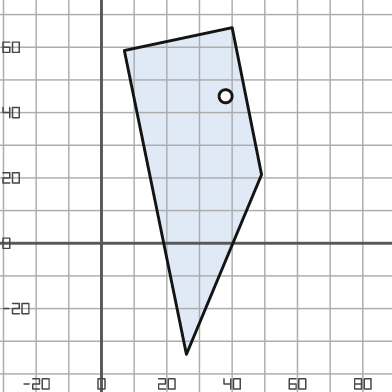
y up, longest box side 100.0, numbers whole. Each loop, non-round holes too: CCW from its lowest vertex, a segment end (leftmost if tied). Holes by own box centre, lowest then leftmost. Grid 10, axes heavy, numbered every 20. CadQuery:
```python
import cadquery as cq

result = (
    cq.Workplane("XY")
    .moveTo(26.0, -34.0)
    .lineTo(49.0, 21.0)
    .lineTo(40.0, 66.0)
    .lineTo(7.0, 59.0)
    .close()
    .moveTo(38.0, 45.0)
    .circle(2.0)
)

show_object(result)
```